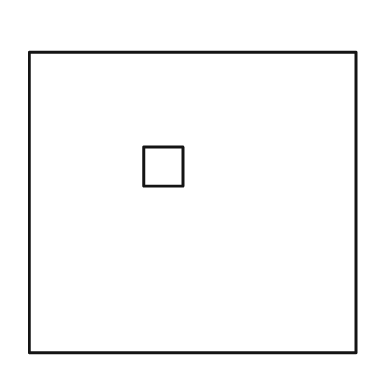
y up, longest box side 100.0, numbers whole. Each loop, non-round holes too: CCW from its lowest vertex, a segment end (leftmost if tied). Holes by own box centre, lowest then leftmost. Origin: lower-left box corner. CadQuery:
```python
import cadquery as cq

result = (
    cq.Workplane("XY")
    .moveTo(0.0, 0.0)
    .lineTo(100.0, 0.0)
    .lineTo(100.0, 92.0)
    .lineTo(0.0, 92.0)
    .close()
    .moveTo(35.0, 51.0)
    .lineTo(47.0, 51.0)
    .lineTo(47.0, 63.0)
    .lineTo(35.0, 63.0)
    .close()
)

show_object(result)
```